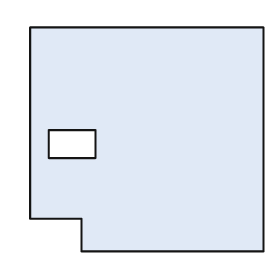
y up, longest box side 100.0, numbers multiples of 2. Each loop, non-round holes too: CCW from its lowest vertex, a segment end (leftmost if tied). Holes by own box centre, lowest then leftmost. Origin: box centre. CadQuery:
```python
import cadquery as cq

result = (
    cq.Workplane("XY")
    .moveTo(-28.0, -48.0)
    .lineTo(50.0, -48.0)
    .lineTo(50.0, 48.0)
    .lineTo(-50.0, 48.0)
    .lineTo(-50.0, -34.0)
    .lineTo(-28.0, -34.0)
    .close()
    .moveTo(-42.0, -8.0)
    .lineTo(-22.0, -8.0)
    .lineTo(-22.0, 4.0)
    .lineTo(-42.0, 4.0)
    .close()
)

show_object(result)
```